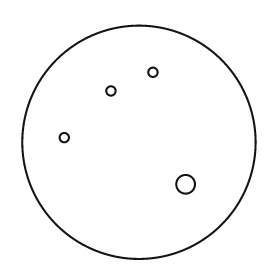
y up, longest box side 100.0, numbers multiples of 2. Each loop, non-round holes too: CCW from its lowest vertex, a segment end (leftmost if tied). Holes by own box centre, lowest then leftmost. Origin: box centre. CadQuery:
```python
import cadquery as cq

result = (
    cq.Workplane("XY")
    .moveTo(0.0, 0.0)
    .circle(50.0)
    .moveTo(20.0, -18.0)
    .circle(4.0)
    .moveTo(-32.0, 2.0)
    .circle(2.0)
    .moveTo(-12.0, 22.0)
    .circle(2.0)
    .moveTo(6.0, 30.0)
    .circle(2.0)
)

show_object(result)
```